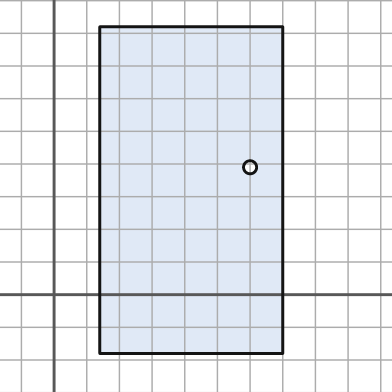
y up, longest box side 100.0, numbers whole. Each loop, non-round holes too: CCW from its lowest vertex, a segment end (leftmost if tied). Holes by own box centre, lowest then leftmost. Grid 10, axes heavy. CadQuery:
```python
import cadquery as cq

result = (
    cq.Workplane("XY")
    .moveTo(14.0, -18.0)
    .lineTo(70.0, -18.0)
    .lineTo(70.0, 82.0)
    .lineTo(14.0, 82.0)
    .close()
    .moveTo(60.0, 39.0)
    .circle(2.0)
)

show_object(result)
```